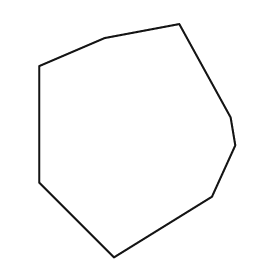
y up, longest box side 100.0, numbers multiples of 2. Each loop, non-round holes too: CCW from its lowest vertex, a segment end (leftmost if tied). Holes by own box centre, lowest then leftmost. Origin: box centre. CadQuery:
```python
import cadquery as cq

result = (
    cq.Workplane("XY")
    .moveTo(-10.0, -50.0)
    .lineTo(32.0, -24.0)
    .lineTo(42.0, -2.0)
    .lineTo(40.0, 10.0)
    .lineTo(18.0, 50.0)
    .lineTo(-14.0, 44.0)
    .lineTo(-42.0, 32.0)
    .lineTo(-42.0, -18.0)
    .close()
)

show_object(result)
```